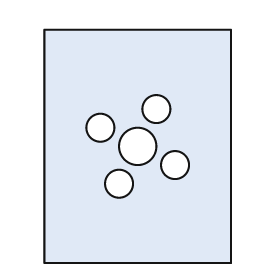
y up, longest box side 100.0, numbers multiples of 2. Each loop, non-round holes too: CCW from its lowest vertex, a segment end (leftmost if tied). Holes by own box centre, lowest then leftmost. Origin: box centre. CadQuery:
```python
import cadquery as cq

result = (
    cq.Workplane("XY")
    .moveTo(-40.0, -50.0)
    .lineTo(40.0, -50.0)
    .lineTo(40.0, 50.0)
    .lineTo(-40.0, 50.0)
    .close()
    .moveTo(-8.0, -16.0)
    .circle(6.0)
    .moveTo(16.0, -8.0)
    .circle(6.0)
    .moveTo(0.0, 0.0)
    .circle(8.0)
    .moveTo(-16.0, 8.0)
    .circle(6.0)
    .moveTo(8.0, 16.0)
    .circle(6.0)
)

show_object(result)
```